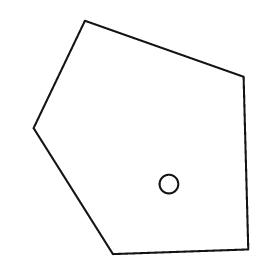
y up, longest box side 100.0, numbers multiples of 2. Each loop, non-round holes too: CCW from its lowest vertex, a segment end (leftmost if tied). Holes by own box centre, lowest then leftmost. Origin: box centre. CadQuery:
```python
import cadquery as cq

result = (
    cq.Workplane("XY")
    .moveTo(-12.0, -50.0)
    .lineTo(46.0, -48.0)
    .lineTo(44.0, 26.0)
    .lineTo(-24.0, 50.0)
    .lineTo(-46.0, 4.0)
    .close()
    .moveTo(12.0, -20.0)
    .circle(4.0)
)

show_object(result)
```